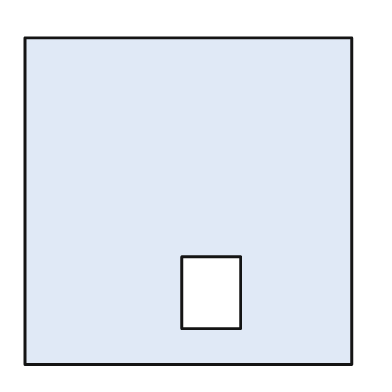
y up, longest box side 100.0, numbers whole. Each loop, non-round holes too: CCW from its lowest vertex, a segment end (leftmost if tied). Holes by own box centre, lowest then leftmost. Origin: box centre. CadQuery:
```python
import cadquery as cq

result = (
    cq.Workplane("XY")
    .moveTo(-50.0, -50.0)
    .lineTo(50.0, -50.0)
    .lineTo(50.0, 50.0)
    .lineTo(-50.0, 50.0)
    .close()
    .moveTo(-2.0, -39.0)
    .lineTo(16.0, -39.0)
    .lineTo(16.0, -17.0)
    .lineTo(-2.0, -17.0)
    .close()
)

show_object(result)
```